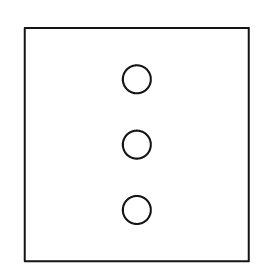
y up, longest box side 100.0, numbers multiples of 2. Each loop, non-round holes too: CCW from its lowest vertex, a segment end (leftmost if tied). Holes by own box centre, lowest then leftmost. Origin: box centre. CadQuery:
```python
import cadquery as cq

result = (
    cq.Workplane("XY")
    .moveTo(-48.0, -50.0)
    .lineTo(48.0, -50.0)
    .lineTo(48.0, 50.0)
    .lineTo(-48.0, 50.0)
    .close()
    .moveTo(0.0, -28.0)
    .circle(6.0)
    .moveTo(0.0, 0.0)
    .circle(6.0)
    .moveTo(0.0, 28.0)
    .circle(6.0)
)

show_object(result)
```